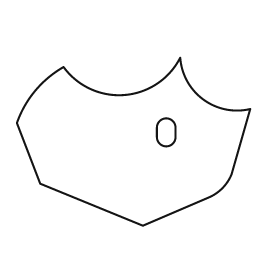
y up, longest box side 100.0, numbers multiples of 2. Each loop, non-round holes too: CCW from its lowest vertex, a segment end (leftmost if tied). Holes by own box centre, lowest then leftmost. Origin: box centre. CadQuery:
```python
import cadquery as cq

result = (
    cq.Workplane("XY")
    .moveTo(4.0, -36.0)
    .lineTo(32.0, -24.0)
    .threePointArc((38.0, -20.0), (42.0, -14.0))
    .lineTo(50.0, 14.0)
    .threePointArc((30.0, 18.0), (20.0, 36.0))
    .threePointArc((-4.0, 20.0), (-30.0, 32.0))
    .threePointArc((-42.0, 22.0), (-50.0, 8.0))
    .lineTo(-40.0, -18.0)
    .close()
    .moveTo(10.0, 2.0)
    .threePointArc((14.0, -2.0), (18.0, 2.0))
    .lineTo(18.0, 6.0)
    .threePointArc((14.0, 10.0), (10.0, 6.0))
    .close()
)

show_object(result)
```